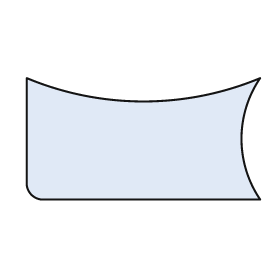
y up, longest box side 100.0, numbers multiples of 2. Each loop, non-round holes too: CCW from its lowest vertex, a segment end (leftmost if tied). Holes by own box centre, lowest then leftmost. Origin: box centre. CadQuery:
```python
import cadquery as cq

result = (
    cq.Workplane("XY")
    .moveTo(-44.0, -26.0)
    .lineTo(50.0, -26.0)
    .threePointArc((42.0, 0.0), (50.0, 26.0))
    .threePointArc((0.0, 16.0), (-50.0, 26.0))
    .lineTo(-50.0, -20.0)
    .threePointArc((-48.0, -24.0), (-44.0, -26.0))
    .close()
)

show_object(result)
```